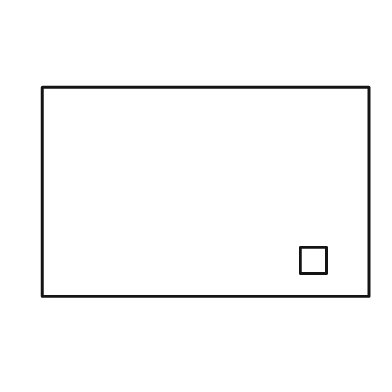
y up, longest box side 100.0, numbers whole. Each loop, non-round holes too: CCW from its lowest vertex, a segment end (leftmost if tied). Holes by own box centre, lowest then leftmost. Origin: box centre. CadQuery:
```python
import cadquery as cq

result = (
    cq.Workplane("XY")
    .moveTo(-50.0, -32.0)
    .lineTo(50.0, -32.0)
    .lineTo(50.0, 32.0)
    .lineTo(-50.0, 32.0)
    .close()
    .moveTo(29.0, -25.0)
    .lineTo(37.0, -25.0)
    .lineTo(37.0, -17.0)
    .lineTo(29.0, -17.0)
    .close()
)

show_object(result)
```